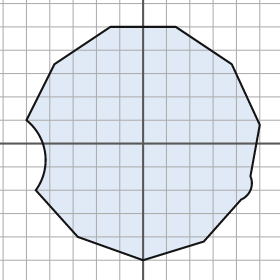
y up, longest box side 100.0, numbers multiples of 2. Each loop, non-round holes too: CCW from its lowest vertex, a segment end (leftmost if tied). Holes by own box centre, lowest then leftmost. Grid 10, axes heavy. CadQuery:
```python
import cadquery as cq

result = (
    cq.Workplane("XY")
    .moveTo(0.0, -50.0)
    .lineTo(26.0, -42.0)
    .lineTo(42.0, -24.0)
    .threePointArc((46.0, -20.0), (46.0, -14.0))
    .lineTo(50.0, 8.0)
    .lineTo(38.0, 34.0)
    .lineTo(14.0, 50.0)
    .lineTo(-14.0, 50.0)
    .lineTo(-38.0, 34.0)
    .lineTo(-50.0, 10.0)
    .threePointArc((-42.0, -4.0), (-46.0, -20.0))
    .lineTo(-28.0, -40.0)
    .close()
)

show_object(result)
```